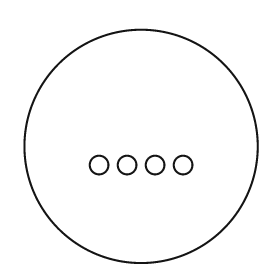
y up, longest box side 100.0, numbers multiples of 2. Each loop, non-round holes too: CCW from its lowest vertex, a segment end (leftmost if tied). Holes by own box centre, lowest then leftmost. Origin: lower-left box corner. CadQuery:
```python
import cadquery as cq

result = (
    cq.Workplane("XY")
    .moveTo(50.0, 50.0)
    .circle(50.0)
    .moveTo(32.0, 42.0)
    .circle(4.0)
    .moveTo(44.0, 42.0)
    .circle(4.0)
    .moveTo(56.0, 42.0)
    .circle(4.0)
    .moveTo(68.0, 42.0)
    .circle(4.0)
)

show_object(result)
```